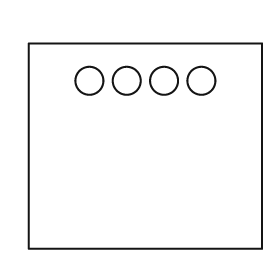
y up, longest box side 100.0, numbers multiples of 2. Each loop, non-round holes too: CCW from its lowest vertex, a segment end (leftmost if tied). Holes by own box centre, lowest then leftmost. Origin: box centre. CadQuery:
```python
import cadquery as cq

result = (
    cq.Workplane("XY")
    .moveTo(-50.0, -44.0)
    .lineTo(50.0, -44.0)
    .lineTo(50.0, 44.0)
    .lineTo(-50.0, 44.0)
    .close()
    .moveTo(-24.0, 28.0)
    .circle(6.0)
    .moveTo(-8.0, 28.0)
    .circle(6.0)
    .moveTo(8.0, 28.0)
    .circle(6.0)
    .moveTo(24.0, 28.0)
    .circle(6.0)
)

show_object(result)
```